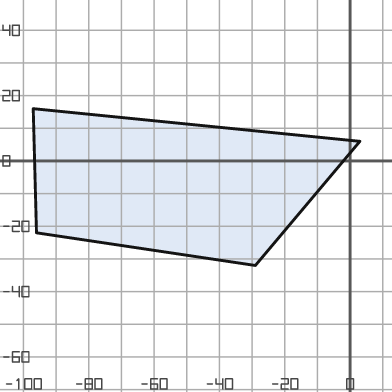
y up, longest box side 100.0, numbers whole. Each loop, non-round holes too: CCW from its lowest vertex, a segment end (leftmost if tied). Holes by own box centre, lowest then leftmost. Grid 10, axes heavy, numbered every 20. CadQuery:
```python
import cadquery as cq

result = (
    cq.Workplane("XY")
    .moveTo(-29.0, -32.0)
    .lineTo(3.0, 6.0)
    .lineTo(-97.0, 16.0)
    .lineTo(-96.0, -22.0)
    .close()
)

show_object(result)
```